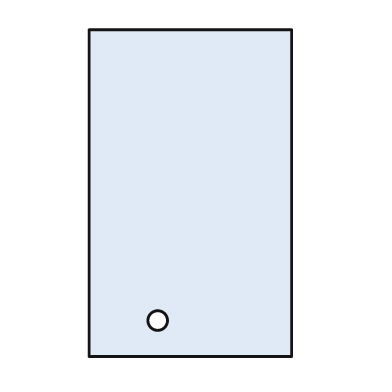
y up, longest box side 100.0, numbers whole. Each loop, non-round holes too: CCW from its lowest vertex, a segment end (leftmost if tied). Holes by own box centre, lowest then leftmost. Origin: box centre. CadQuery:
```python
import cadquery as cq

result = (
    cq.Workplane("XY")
    .moveTo(-31.0, -50.0)
    .lineTo(31.0, -50.0)
    .lineTo(31.0, 50.0)
    .lineTo(-31.0, 50.0)
    .close()
    .moveTo(-10.0, -39.0)
    .circle(3.0)
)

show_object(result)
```